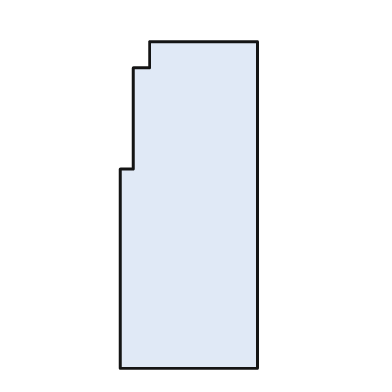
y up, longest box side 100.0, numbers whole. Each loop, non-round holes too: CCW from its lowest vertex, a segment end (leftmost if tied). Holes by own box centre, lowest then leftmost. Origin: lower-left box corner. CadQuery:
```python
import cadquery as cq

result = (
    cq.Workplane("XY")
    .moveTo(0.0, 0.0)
    .lineTo(42.0, 0.0)
    .lineTo(42.0, 100.0)
    .lineTo(9.0, 100.0)
    .lineTo(9.0, 92.0)
    .lineTo(4.0, 92.0)
    .lineTo(4.0, 61.0)
    .lineTo(0.0, 61.0)
    .close()
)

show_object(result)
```